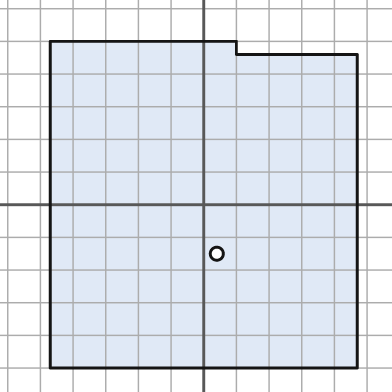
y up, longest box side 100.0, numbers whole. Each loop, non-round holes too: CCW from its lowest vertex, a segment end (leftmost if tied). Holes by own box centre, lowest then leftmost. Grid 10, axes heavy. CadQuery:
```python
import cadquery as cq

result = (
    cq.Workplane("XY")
    .moveTo(-47.0, -50.0)
    .lineTo(47.0, -50.0)
    .lineTo(47.0, 46.0)
    .lineTo(10.0, 46.0)
    .lineTo(10.0, 50.0)
    .lineTo(-47.0, 50.0)
    .close()
    .moveTo(4.0, -15.0)
    .circle(2.0)
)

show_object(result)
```